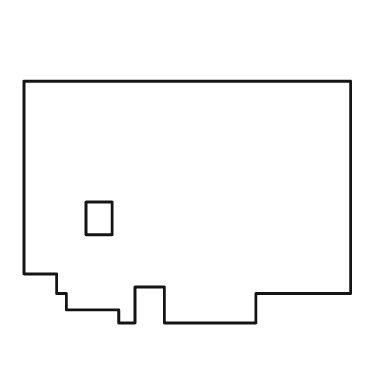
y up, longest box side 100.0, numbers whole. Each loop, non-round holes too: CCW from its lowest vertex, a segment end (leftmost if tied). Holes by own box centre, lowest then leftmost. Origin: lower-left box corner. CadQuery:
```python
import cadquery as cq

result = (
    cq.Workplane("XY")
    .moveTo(29.0, 0.0)
    .lineTo(34.0, 0.0)
    .lineTo(34.0, 11.0)
    .lineTo(43.0, 11.0)
    .lineTo(43.0, 0.0)
    .lineTo(71.0, 0.0)
    .lineTo(71.0, 9.0)
    .lineTo(100.0, 9.0)
    .lineTo(100.0, 74.0)
    .lineTo(0.0, 74.0)
    .lineTo(0.0, 15.0)
    .lineTo(10.0, 15.0)
    .lineTo(10.0, 9.0)
    .lineTo(13.0, 9.0)
    .lineTo(13.0, 4.0)
    .lineTo(29.0, 4.0)
    .close()
    .moveTo(19.0, 27.0)
    .lineTo(27.0, 27.0)
    .lineTo(27.0, 37.0)
    .lineTo(19.0, 37.0)
    .close()
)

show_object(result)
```